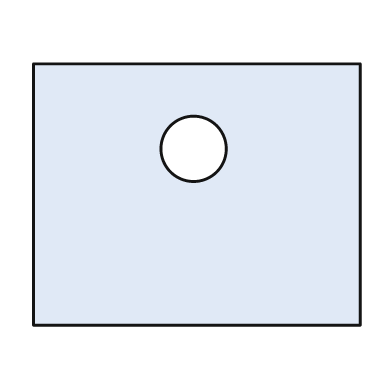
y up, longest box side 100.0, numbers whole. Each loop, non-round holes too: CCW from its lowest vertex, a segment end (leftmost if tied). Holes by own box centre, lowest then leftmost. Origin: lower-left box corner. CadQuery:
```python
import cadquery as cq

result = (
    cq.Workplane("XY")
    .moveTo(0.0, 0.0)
    .lineTo(100.0, 0.0)
    .lineTo(100.0, 80.0)
    .lineTo(0.0, 80.0)
    .close()
    .moveTo(49.0, 54.0)
    .circle(10.0)
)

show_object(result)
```